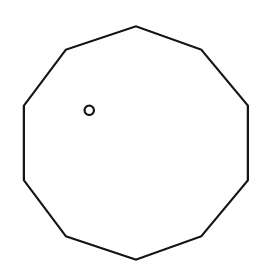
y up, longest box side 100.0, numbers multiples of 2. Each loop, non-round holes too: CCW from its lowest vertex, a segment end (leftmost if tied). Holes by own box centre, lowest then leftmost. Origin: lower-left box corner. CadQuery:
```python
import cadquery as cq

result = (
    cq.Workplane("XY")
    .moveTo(48.0, 0.0)
    .lineTo(76.0, 10.0)
    .lineTo(96.0, 34.0)
    .lineTo(96.0, 66.0)
    .lineTo(76.0, 90.0)
    .lineTo(48.0, 100.0)
    .lineTo(18.0, 90.0)
    .lineTo(0.0, 66.0)
    .lineTo(0.0, 34.0)
    .lineTo(18.0, 10.0)
    .close()
    .moveTo(28.0, 64.0)
    .circle(2.0)
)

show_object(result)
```